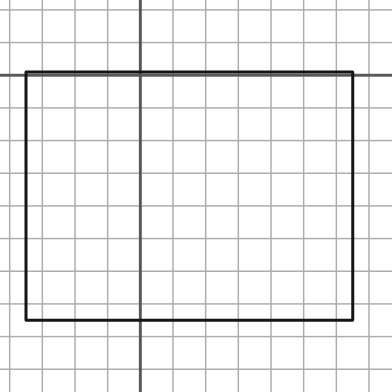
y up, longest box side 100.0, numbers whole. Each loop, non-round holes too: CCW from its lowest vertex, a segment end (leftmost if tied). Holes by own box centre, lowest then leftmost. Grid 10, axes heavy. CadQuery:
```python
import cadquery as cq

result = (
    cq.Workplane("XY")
    .moveTo(-35.0, -75.0)
    .lineTo(65.0, -75.0)
    .lineTo(65.0, 1.0)
    .lineTo(-35.0, 1.0)
    .close()
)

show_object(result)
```